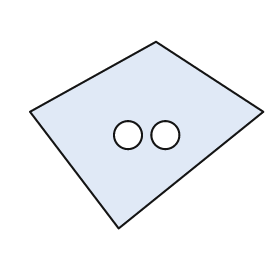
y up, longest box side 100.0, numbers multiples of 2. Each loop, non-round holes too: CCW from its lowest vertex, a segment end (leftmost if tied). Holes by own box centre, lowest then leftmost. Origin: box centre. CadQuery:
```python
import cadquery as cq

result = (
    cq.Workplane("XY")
    .moveTo(-12.0, -40.0)
    .lineTo(50.0, 10.0)
    .lineTo(4.0, 40.0)
    .lineTo(-50.0, 10.0)
    .close()
    .moveTo(-8.0, 0.0)
    .circle(6.0)
    .moveTo(8.0, 0.0)
    .circle(6.0)
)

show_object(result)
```